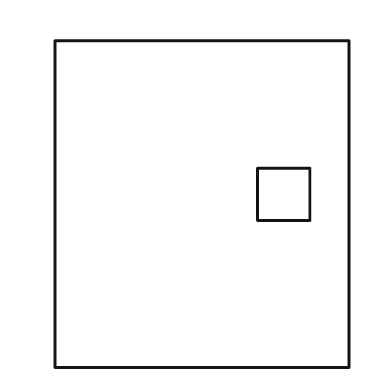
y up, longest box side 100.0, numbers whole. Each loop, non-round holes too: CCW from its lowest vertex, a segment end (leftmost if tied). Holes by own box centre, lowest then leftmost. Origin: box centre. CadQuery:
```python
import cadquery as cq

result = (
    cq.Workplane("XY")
    .moveTo(-45.0, -50.0)
    .lineTo(45.0, -50.0)
    .lineTo(45.0, 50.0)
    .lineTo(-45.0, 50.0)
    .close()
    .moveTo(17.0, -5.0)
    .lineTo(33.0, -5.0)
    .lineTo(33.0, 11.0)
    .lineTo(17.0, 11.0)
    .close()
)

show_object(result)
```